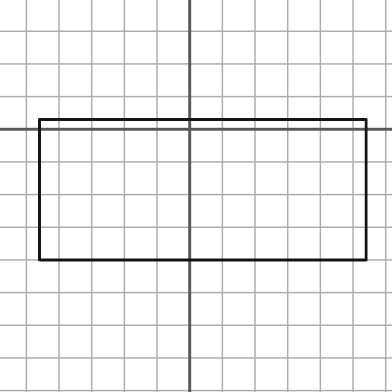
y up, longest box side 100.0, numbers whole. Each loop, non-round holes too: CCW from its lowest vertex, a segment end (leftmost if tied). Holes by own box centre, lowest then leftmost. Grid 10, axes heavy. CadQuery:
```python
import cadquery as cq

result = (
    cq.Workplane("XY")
    .moveTo(-46.0, -40.0)
    .lineTo(54.0, -40.0)
    .lineTo(54.0, 3.0)
    .lineTo(-46.0, 3.0)
    .close()
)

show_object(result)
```